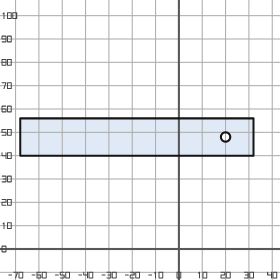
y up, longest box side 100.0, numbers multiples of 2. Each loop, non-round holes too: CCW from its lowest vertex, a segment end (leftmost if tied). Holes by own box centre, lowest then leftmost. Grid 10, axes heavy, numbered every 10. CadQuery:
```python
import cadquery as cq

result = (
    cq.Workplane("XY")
    .moveTo(-68.0, 40.0)
    .lineTo(32.0, 40.0)
    .lineTo(32.0, 56.0)
    .lineTo(-68.0, 56.0)
    .close()
    .moveTo(20.0, 48.0)
    .circle(2.0)
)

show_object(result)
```